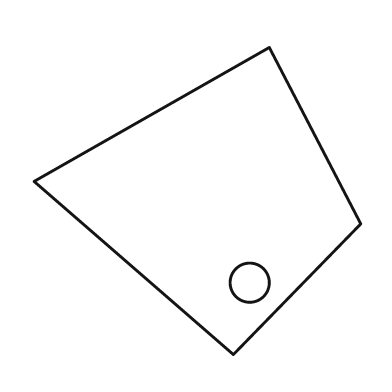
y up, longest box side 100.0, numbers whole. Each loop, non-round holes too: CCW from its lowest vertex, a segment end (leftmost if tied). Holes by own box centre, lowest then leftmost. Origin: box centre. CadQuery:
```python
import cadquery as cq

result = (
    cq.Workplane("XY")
    .moveTo(11.0, -47.0)
    .lineTo(50.0, -7.0)
    .lineTo(22.0, 47.0)
    .lineTo(-50.0, 6.0)
    .close()
    .moveTo(16.0, -25.0)
    .circle(6.0)
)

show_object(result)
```